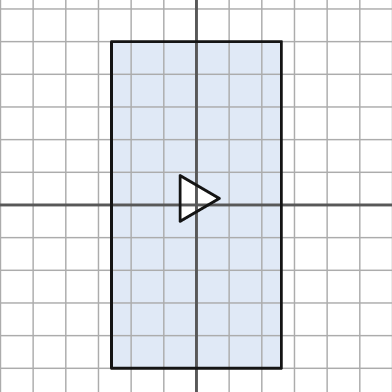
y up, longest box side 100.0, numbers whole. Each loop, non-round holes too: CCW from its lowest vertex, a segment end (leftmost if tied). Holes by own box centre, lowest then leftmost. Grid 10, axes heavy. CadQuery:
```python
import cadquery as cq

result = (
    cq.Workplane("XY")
    .moveTo(-26.0, -50.0)
    .lineTo(26.0, -50.0)
    .lineTo(26.0, 50.0)
    .lineTo(-26.0, 50.0)
    .close()
    .moveTo(-5.0, -5.0)
    .lineTo(7.0, 2.0)
    .lineTo(-5.0, 9.0)
    .close()
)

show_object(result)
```